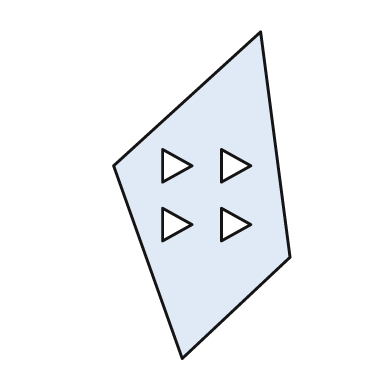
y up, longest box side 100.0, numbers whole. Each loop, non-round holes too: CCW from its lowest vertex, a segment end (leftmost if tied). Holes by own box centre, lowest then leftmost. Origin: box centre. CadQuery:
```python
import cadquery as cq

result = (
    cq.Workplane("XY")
    .moveTo(-6.0, -50.0)
    .lineTo(27.0, -19.0)
    .lineTo(18.0, 50.0)
    .lineTo(-27.0, 9.0)
    .close()
    .moveTo(-12.0, -14.0)
    .lineTo(-3.0, -9.0)
    .lineTo(-12.0, -4.0)
    .close()
    .moveTo(6.0, -14.0)
    .lineTo(15.0, -9.0)
    .lineTo(6.0, -4.0)
    .close()
    .moveTo(-12.0, 4.0)
    .lineTo(-3.0, 9.0)
    .lineTo(-12.0, 14.0)
    .close()
    .moveTo(6.0, 4.0)
    .lineTo(15.0, 9.0)
    .lineTo(6.0, 14.0)
    .close()
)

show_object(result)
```